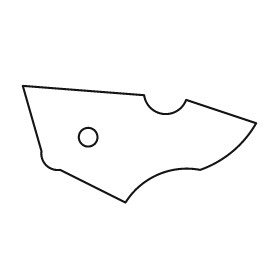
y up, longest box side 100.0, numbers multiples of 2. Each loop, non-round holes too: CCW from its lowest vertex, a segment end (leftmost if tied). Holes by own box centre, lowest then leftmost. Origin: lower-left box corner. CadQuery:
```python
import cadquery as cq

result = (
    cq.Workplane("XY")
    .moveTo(44.0, 0.0)
    .threePointArc((58.0, 12.0), (76.0, 14.0))
    .threePointArc((90.0, 22.0), (100.0, 34.0))
    .lineTo(70.0, 44.0)
    .threePointArc((60.0, 38.0), (52.0, 46.0))
    .lineTo(0.0, 50.0)
    .lineTo(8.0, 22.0)
    .threePointArc((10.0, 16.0), (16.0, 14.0))
    .close()
    .moveTo(28.0, 28.0)
    .circle(4.0)
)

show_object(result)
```